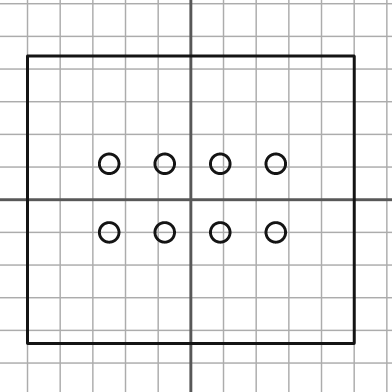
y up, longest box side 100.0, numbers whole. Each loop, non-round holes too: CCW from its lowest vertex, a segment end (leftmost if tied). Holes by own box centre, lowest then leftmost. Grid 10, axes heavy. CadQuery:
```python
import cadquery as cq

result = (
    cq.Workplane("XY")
    .moveTo(-50.0, -44.0)
    .lineTo(50.0, -44.0)
    .lineTo(50.0, 44.0)
    .lineTo(-50.0, 44.0)
    .close()
    .moveTo(-25.0, -10.0)
    .circle(3.0)
    .moveTo(-8.0, -10.0)
    .circle(3.0)
    .moveTo(9.0, -10.0)
    .circle(3.0)
    .moveTo(26.0, -10.0)
    .circle(3.0)
    .moveTo(-25.0, 11.0)
    .circle(3.0)
    .moveTo(-8.0, 11.0)
    .circle(3.0)
    .moveTo(9.0, 11.0)
    .circle(3.0)
    .moveTo(26.0, 11.0)
    .circle(3.0)
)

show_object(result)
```